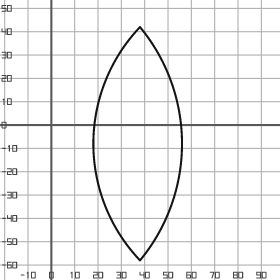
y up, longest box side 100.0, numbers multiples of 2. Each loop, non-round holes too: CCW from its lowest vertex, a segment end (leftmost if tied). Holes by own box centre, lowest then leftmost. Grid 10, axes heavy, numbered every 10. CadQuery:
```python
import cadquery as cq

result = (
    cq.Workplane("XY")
    .moveTo(38.0, -58.0)
    .threePointArc((56.0, -8.0), (38.0, 42.0))
    .threePointArc((18.0, -8.0), (38.0, -58.0))
    .close()
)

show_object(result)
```